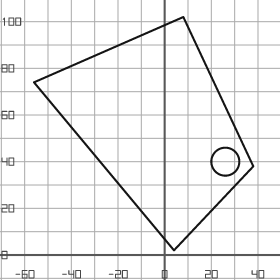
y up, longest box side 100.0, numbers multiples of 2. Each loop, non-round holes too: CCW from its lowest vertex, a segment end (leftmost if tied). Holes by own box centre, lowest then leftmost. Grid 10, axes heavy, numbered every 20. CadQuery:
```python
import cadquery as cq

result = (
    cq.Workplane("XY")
    .moveTo(4.0, 2.0)
    .lineTo(38.0, 38.0)
    .lineTo(8.0, 102.0)
    .lineTo(-56.0, 74.0)
    .close()
    .moveTo(26.0, 40.0)
    .circle(6.0)
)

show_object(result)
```